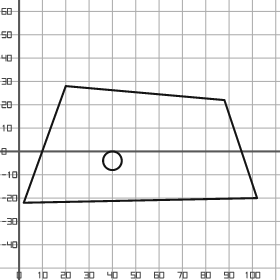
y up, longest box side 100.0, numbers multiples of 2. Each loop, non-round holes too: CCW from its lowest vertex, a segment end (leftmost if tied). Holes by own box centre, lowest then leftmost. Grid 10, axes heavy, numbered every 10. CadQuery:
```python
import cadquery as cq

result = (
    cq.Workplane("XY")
    .moveTo(2.0, -22.0)
    .lineTo(102.0, -20.0)
    .lineTo(88.0, 22.0)
    .lineTo(20.0, 28.0)
    .close()
    .moveTo(40.0, -4.0)
    .circle(4.0)
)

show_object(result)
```